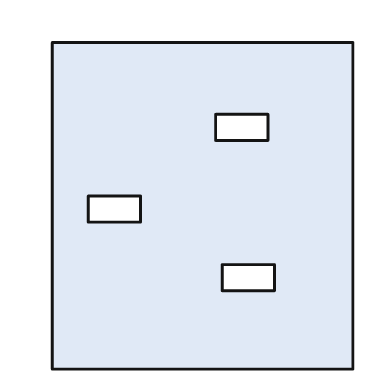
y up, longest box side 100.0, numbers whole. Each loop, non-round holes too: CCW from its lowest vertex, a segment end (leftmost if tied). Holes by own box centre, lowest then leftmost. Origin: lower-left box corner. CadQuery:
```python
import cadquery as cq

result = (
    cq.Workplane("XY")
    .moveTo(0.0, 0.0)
    .lineTo(92.0, 0.0)
    .lineTo(92.0, 100.0)
    .lineTo(0.0, 100.0)
    .close()
    .moveTo(52.0, 24.0)
    .lineTo(68.0, 24.0)
    .lineTo(68.0, 32.0)
    .lineTo(52.0, 32.0)
    .close()
    .moveTo(11.0, 45.0)
    .lineTo(27.0, 45.0)
    .lineTo(27.0, 53.0)
    .lineTo(11.0, 53.0)
    .close()
    .moveTo(50.0, 70.0)
    .lineTo(66.0, 70.0)
    .lineTo(66.0, 78.0)
    .lineTo(50.0, 78.0)
    .close()
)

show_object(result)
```